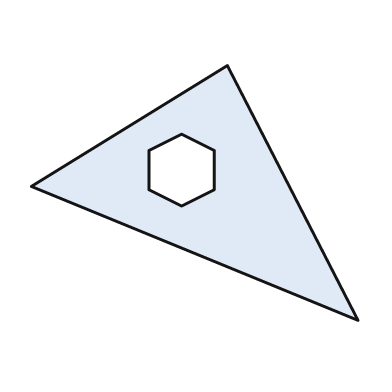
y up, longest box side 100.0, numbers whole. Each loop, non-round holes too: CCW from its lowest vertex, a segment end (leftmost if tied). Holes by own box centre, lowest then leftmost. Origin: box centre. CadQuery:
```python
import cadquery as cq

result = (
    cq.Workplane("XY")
    .moveTo(50.0, -39.0)
    .lineTo(10.0, 39.0)
    .lineTo(-50.0, 2.0)
    .close()
    .moveTo(-4.0, -4.0)
    .lineTo(6.0, 1.0)
    .lineTo(6.0, 13.0)
    .lineTo(-4.0, 18.0)
    .lineTo(-14.0, 13.0)
    .lineTo(-14.0, 1.0)
    .close()
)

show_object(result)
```